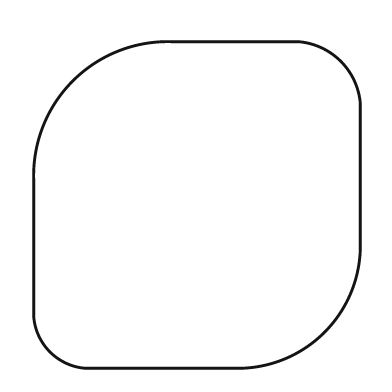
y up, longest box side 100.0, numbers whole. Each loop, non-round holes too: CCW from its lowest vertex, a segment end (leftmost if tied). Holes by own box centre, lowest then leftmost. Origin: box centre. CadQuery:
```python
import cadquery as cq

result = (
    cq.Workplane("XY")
    .moveTo(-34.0, -50.0)
    .lineTo(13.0, -50.0)
    .threePointArc((39.0, -39.0), (50.0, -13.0))
    .lineTo(50.0, 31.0)
    .threePointArc((44.0, 44.0), (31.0, 50.0))
    .lineTo(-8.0, 50.0)
    .threePointArc((-38.0, 38.0), (-50.0, 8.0))
    .lineTo(-50.0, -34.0)
    .threePointArc((-45.0, -45.0), (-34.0, -50.0))
    .close()
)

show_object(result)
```